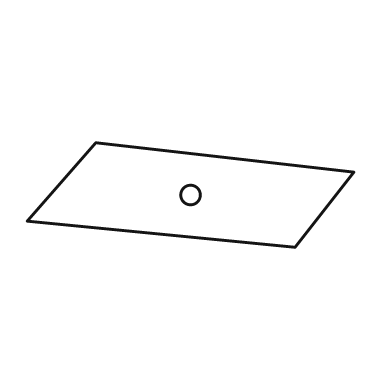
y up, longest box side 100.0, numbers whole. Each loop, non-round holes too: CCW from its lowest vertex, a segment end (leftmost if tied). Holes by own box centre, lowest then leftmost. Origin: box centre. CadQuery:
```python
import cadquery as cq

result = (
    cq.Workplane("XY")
    .moveTo(32.0, -16.0)
    .lineTo(50.0, 7.0)
    .lineTo(-29.0, 16.0)
    .lineTo(-50.0, -8.0)
    .close()
    .moveTo(0.0, 0.0)
    .circle(3.0)
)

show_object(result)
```